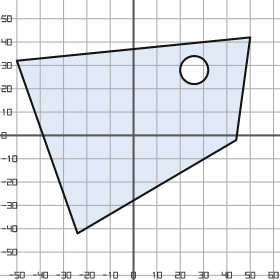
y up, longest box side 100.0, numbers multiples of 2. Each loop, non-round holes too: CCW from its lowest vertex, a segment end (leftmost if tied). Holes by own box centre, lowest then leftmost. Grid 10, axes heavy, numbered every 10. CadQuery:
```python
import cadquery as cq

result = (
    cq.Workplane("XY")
    .moveTo(-24.0, -42.0)
    .lineTo(44.0, -2.0)
    .lineTo(50.0, 42.0)
    .lineTo(-50.0, 32.0)
    .close()
    .moveTo(26.0, 28.0)
    .circle(6.0)
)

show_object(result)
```